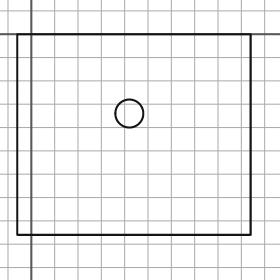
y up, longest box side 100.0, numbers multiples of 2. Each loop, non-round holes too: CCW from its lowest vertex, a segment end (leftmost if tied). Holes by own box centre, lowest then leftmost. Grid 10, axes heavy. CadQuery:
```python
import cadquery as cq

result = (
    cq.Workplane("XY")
    .moveTo(-6.0, -86.0)
    .lineTo(94.0, -86.0)
    .lineTo(94.0, 0.0)
    .lineTo(-6.0, 0.0)
    .close()
    .moveTo(42.0, -34.0)
    .circle(6.0)
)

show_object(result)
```